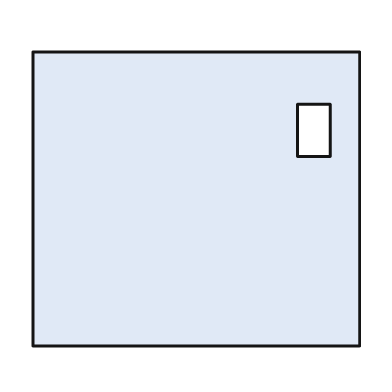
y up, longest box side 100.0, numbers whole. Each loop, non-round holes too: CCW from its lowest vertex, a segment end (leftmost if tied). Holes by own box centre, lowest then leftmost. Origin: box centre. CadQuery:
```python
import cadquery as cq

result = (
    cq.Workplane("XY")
    .moveTo(-50.0, -45.0)
    .lineTo(50.0, -45.0)
    .lineTo(50.0, 45.0)
    .lineTo(-50.0, 45.0)
    .close()
    .moveTo(31.0, 13.0)
    .lineTo(41.0, 13.0)
    .lineTo(41.0, 29.0)
    .lineTo(31.0, 29.0)
    .close()
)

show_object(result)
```